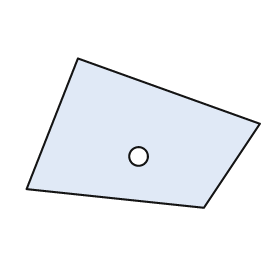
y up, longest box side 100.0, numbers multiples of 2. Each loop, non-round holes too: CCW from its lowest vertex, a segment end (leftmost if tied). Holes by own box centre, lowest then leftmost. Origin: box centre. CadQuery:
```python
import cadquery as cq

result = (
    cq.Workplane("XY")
    .moveTo(26.0, -32.0)
    .lineTo(50.0, 4.0)
    .lineTo(-28.0, 32.0)
    .lineTo(-50.0, -24.0)
    .close()
    .moveTo(-2.0, -10.0)
    .circle(4.0)
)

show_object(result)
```